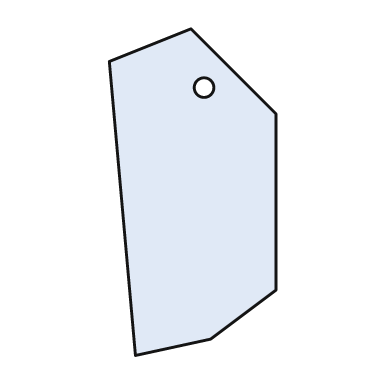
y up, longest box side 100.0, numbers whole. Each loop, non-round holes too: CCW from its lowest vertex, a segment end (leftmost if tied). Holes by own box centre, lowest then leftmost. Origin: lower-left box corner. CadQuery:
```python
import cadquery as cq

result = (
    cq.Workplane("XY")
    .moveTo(8.0, 0.0)
    .lineTo(31.0, 5.0)
    .lineTo(51.0, 20.0)
    .lineTo(51.0, 74.0)
    .lineTo(25.0, 100.0)
    .lineTo(0.0, 90.0)
    .close()
    .moveTo(29.0, 82.0)
    .circle(3.0)
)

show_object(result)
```